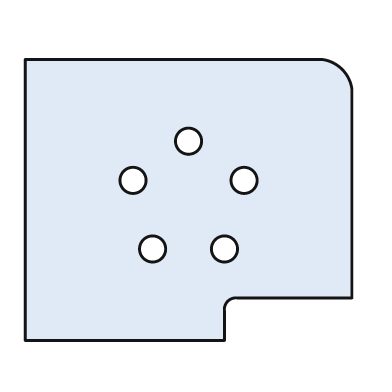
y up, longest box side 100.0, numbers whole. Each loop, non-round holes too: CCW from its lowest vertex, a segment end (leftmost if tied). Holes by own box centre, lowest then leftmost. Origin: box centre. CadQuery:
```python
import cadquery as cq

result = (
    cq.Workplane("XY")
    .moveTo(-50.0, -43.0)
    .lineTo(11.0, -43.0)
    .lineTo(11.0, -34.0)
    .threePointArc((12.0, -31.0), (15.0, -30.0))
    .lineTo(50.0, -30.0)
    .lineTo(50.0, 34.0)
    .threePointArc((47.0, 40.0), (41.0, 43.0))
    .lineTo(-50.0, 43.0)
    .close()
    .moveTo(-11.0, -15.0)
    .circle(4.0)
    .moveTo(11.0, -15.0)
    .circle(4.0)
    .moveTo(-17.0, 6.0)
    .circle(4.0)
    .moveTo(17.0, 6.0)
    .circle(4.0)
    .moveTo(0.0, 18.0)
    .circle(4.0)
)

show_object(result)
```